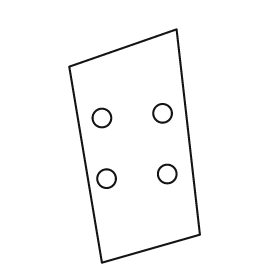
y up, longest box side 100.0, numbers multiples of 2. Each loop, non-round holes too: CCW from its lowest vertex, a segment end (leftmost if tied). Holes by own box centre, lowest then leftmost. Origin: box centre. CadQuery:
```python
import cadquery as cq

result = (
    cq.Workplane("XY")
    .moveTo(-14.0, -50.0)
    .lineTo(28.0, -38.0)
    .lineTo(18.0, 50.0)
    .lineTo(-28.0, 34.0)
    .close()
    .moveTo(-12.0, -14.0)
    .circle(4.0)
    .moveTo(14.0, -12.0)
    .circle(4.0)
    .moveTo(-14.0, 12.0)
    .circle(4.0)
    .moveTo(12.0, 14.0)
    .circle(4.0)
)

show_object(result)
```